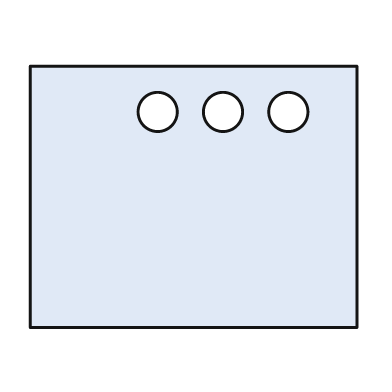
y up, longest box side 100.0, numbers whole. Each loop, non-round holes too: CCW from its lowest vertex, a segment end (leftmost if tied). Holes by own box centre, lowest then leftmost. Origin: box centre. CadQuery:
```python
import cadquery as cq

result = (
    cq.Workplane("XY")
    .moveTo(-50.0, -40.0)
    .lineTo(50.0, -40.0)
    .lineTo(50.0, 40.0)
    .lineTo(-50.0, 40.0)
    .close()
    .moveTo(-11.0, 26.0)
    .circle(6.0)
    .moveTo(9.0, 26.0)
    .circle(6.0)
    .moveTo(29.0, 26.0)
    .circle(6.0)
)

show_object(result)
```